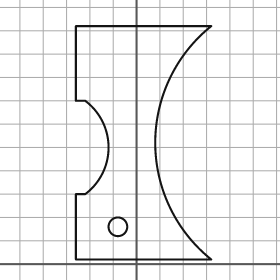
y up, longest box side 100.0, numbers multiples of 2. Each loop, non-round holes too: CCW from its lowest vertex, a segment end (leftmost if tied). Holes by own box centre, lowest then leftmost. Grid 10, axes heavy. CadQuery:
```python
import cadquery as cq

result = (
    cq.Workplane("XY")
    .moveTo(-26.0, 2.0)
    .lineTo(32.0, 2.0)
    .threePointArc((8.0, 52.0), (32.0, 102.0))
    .lineTo(-26.0, 102.0)
    .lineTo(-26.0, 70.0)
    .lineTo(-22.0, 70.0)
    .threePointArc((-12.0, 50.0), (-22.0, 30.0))
    .lineTo(-26.0, 30.0)
    .close()
    .moveTo(-8.0, 16.0)
    .circle(4.0)
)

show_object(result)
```